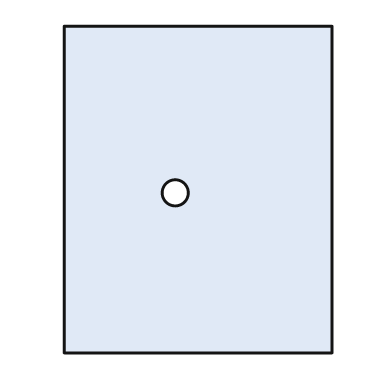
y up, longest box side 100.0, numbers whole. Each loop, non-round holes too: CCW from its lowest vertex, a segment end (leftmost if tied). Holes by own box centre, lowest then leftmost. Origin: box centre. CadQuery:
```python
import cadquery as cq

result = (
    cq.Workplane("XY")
    .moveTo(-41.0, -50.0)
    .lineTo(41.0, -50.0)
    .lineTo(41.0, 50.0)
    .lineTo(-41.0, 50.0)
    .close()
    .moveTo(-7.0, -1.0)
    .circle(4.0)
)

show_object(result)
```